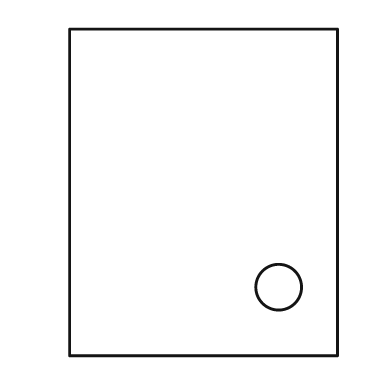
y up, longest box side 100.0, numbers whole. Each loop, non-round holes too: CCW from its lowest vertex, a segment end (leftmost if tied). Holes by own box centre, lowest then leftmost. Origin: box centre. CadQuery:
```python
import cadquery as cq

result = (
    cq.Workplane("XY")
    .moveTo(-41.0, -50.0)
    .lineTo(41.0, -50.0)
    .lineTo(41.0, 50.0)
    .lineTo(-41.0, 50.0)
    .close()
    .moveTo(23.0, -29.0)
    .circle(7.0)
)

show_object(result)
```